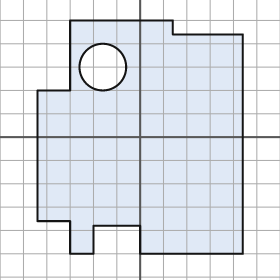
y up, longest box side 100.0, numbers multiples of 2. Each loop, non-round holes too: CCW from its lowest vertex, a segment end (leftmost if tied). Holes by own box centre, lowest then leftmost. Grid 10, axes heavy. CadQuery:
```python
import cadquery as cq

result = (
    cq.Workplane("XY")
    .moveTo(-30.0, -50.0)
    .lineTo(-20.0, -50.0)
    .lineTo(-20.0, -38.0)
    .lineTo(0.0, -38.0)
    .lineTo(0.0, -50.0)
    .lineTo(44.0, -50.0)
    .lineTo(44.0, 44.0)
    .lineTo(14.0, 44.0)
    .lineTo(14.0, 50.0)
    .lineTo(-30.0, 50.0)
    .lineTo(-30.0, 20.0)
    .lineTo(-44.0, 20.0)
    .lineTo(-44.0, -36.0)
    .lineTo(-30.0, -36.0)
    .close()
    .moveTo(-16.0, 30.0)
    .circle(10.0)
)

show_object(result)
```